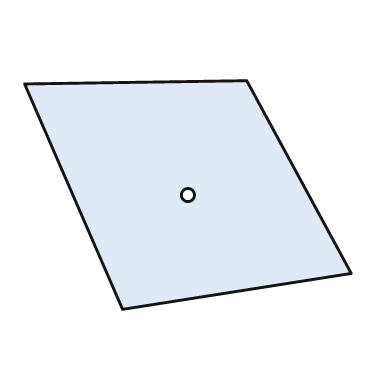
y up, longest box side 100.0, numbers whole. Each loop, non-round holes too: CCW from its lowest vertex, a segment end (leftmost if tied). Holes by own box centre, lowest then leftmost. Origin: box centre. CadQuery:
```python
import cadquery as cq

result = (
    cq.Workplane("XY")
    .moveTo(-20.0, -35.0)
    .lineTo(50.0, -24.0)
    .lineTo(18.0, 35.0)
    .lineTo(-50.0, 34.0)
    .close()
    .moveTo(0.0, 0.0)
    .circle(2.0)
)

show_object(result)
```